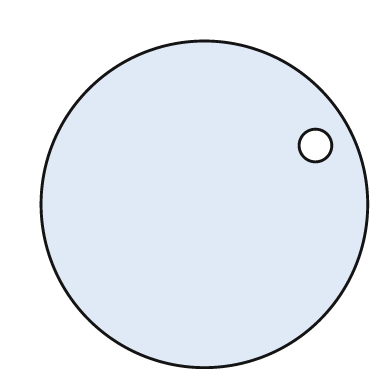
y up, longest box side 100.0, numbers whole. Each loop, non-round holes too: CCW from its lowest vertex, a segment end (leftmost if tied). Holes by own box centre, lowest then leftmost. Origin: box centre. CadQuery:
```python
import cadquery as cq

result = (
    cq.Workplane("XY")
    .moveTo(0.0, 0.0)
    .circle(50.0)
    .moveTo(34.0, 18.0)
    .circle(5.0)
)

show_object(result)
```